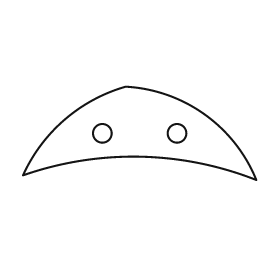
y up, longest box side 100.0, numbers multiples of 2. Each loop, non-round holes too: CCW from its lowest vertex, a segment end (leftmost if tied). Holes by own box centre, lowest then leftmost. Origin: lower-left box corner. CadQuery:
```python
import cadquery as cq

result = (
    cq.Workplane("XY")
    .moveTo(100.0, 0.0)
    .threePointArc((78.0, 28.0), (44.0, 40.0))
    .threePointArc((18.0, 26.0), (0.0, 2.0))
    .threePointArc((50.0, 10.0), (100.0, 0.0))
    .close()
    .moveTo(34.0, 20.0)
    .circle(4.0)
    .moveTo(66.0, 20.0)
    .circle(4.0)
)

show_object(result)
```